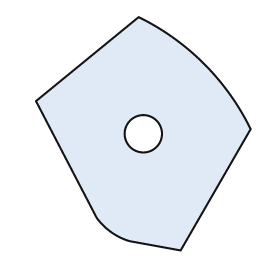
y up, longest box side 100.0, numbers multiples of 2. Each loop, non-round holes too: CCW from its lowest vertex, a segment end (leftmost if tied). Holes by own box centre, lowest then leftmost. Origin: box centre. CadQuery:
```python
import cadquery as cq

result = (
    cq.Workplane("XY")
    .moveTo(16.0, -50.0)
    .lineTo(46.0, 2.0)
    .threePointArc((26.0, 30.0), (-2.0, 50.0))
    .lineTo(-46.0, 14.0)
    .lineTo(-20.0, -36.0)
    .threePointArc((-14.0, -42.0), (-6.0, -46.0))
    .close()
    .moveTo(0.0, 0.0)
    .circle(8.0)
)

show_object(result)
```